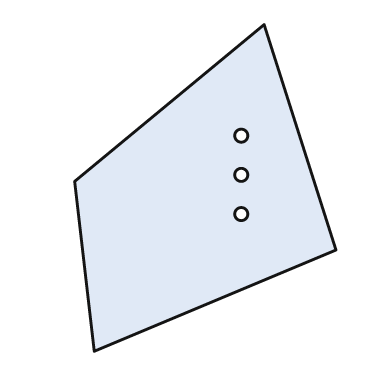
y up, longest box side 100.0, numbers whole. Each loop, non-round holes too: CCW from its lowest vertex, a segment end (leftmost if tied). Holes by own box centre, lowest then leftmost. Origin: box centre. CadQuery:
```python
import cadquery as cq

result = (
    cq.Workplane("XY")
    .moveTo(-34.0, -50.0)
    .lineTo(40.0, -19.0)
    .lineTo(18.0, 50.0)
    .lineTo(-40.0, 2.0)
    .close()
    .moveTo(11.0, -8.0)
    .circle(2.0)
    .moveTo(11.0, 4.0)
    .circle(2.0)
    .moveTo(11.0, 16.0)
    .circle(2.0)
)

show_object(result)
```